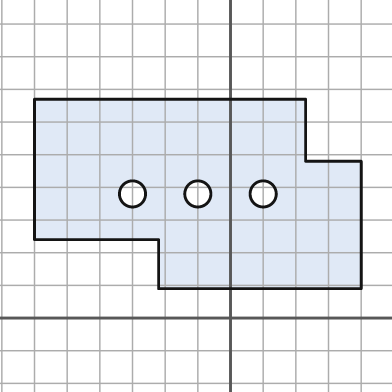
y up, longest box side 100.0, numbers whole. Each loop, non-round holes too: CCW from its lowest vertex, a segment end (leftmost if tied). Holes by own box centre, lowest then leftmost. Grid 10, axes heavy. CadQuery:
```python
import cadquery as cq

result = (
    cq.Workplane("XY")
    .moveTo(-22.0, 9.0)
    .lineTo(40.0, 9.0)
    .lineTo(40.0, 48.0)
    .lineTo(23.0, 48.0)
    .lineTo(23.0, 67.0)
    .lineTo(-60.0, 67.0)
    .lineTo(-60.0, 24.0)
    .lineTo(-22.0, 24.0)
    .close()
    .moveTo(-30.0, 38.0)
    .circle(4.0)
    .moveTo(-10.0, 38.0)
    .circle(4.0)
    .moveTo(10.0, 38.0)
    .circle(4.0)
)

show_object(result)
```